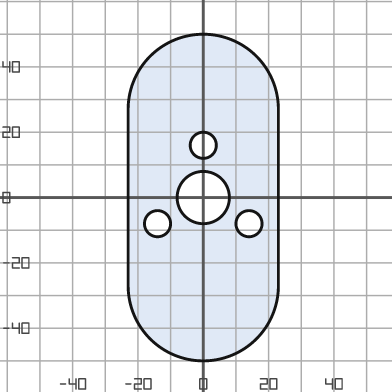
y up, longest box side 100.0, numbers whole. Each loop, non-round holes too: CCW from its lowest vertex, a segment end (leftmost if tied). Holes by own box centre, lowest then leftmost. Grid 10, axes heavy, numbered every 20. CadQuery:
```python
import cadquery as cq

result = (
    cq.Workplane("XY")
    .moveTo(-23.0, -27.0)
    .threePointArc((0.0, -50.0), (23.0, -27.0))
    .lineTo(23.0, 27.0)
    .threePointArc((0.0, 50.0), (-23.0, 27.0))
    .close()
    .moveTo(-14.0, -8.0)
    .circle(4.0)
    .moveTo(14.0, -8.0)
    .circle(4.0)
    .moveTo(0.0, 0.0)
    .circle(8.0)
    .moveTo(0.0, 16.0)
    .circle(4.0)
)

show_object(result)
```